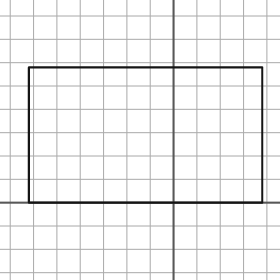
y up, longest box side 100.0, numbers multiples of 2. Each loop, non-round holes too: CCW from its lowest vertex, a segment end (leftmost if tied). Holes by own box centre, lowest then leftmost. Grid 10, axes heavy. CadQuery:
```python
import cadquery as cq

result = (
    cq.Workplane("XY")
    .moveTo(-62.0, 0.0)
    .lineTo(38.0, 0.0)
    .lineTo(38.0, 58.0)
    .lineTo(-62.0, 58.0)
    .close()
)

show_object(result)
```